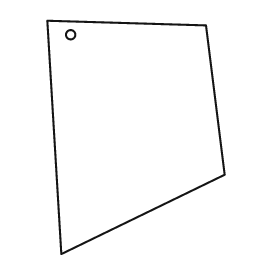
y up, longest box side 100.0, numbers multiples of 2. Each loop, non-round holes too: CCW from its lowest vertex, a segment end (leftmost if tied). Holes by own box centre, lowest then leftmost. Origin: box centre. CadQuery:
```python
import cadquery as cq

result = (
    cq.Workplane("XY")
    .moveTo(-32.0, -50.0)
    .lineTo(38.0, -16.0)
    .lineTo(30.0, 48.0)
    .lineTo(-38.0, 50.0)
    .close()
    .moveTo(-28.0, 44.0)
    .circle(2.0)
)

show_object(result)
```